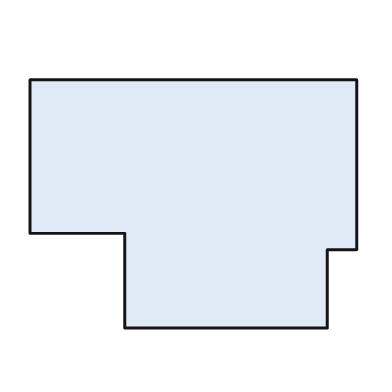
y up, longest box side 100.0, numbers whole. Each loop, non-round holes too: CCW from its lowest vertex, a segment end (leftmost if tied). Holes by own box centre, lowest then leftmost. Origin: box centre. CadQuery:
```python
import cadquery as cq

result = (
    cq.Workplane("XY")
    .moveTo(-21.0, -38.0)
    .lineTo(41.0, -38.0)
    .lineTo(41.0, -14.0)
    .lineTo(50.0, -14.0)
    .lineTo(50.0, 38.0)
    .lineTo(-50.0, 38.0)
    .lineTo(-50.0, -9.0)
    .lineTo(-21.0, -9.0)
    .close()
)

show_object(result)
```